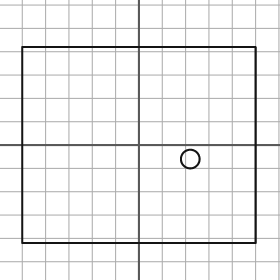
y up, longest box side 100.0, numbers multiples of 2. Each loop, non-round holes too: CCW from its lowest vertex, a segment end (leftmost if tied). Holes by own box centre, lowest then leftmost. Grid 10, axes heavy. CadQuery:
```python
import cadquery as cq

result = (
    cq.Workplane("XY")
    .moveTo(-50.0, -42.0)
    .lineTo(50.0, -42.0)
    .lineTo(50.0, 42.0)
    .lineTo(-50.0, 42.0)
    .close()
    .moveTo(22.0, -6.0)
    .circle(4.0)
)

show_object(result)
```